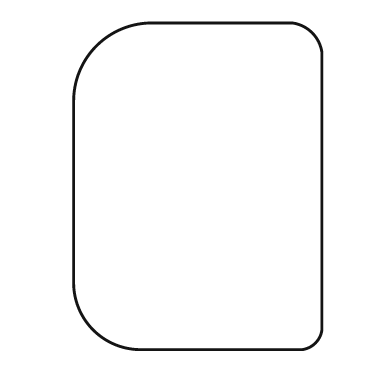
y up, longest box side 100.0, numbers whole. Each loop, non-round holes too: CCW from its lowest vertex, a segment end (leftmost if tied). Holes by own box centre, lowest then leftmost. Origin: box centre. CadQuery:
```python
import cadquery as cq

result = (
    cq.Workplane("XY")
    .moveTo(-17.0, -50.0)
    .lineTo(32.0, -50.0)
    .threePointArc((36.0, -48.0), (38.0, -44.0))
    .lineTo(38.0, 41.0)
    .threePointArc((35.0, 47.0), (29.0, 50.0))
    .lineTo(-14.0, 50.0)
    .threePointArc((-31.0, 43.0), (-38.0, 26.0))
    .lineTo(-38.0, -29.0)
    .threePointArc((-32.0, -44.0), (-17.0, -50.0))
    .close()
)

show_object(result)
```